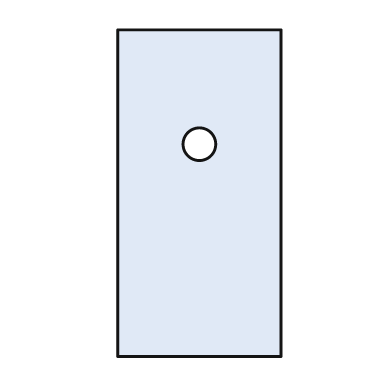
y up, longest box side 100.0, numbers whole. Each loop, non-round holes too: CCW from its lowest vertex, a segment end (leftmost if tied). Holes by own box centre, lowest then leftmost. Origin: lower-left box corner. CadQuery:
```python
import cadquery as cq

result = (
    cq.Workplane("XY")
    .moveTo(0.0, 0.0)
    .lineTo(50.0, 0.0)
    .lineTo(50.0, 100.0)
    .lineTo(0.0, 100.0)
    .close()
    .moveTo(25.0, 65.0)
    .circle(5.0)
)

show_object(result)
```